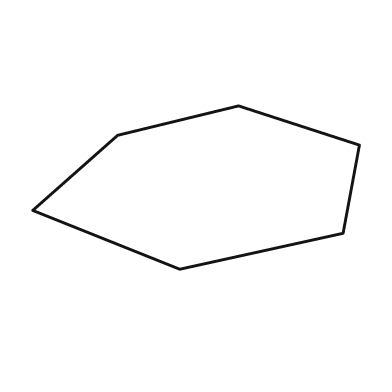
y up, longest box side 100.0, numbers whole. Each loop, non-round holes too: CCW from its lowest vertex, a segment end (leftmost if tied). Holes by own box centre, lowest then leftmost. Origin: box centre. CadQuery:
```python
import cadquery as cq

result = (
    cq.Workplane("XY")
    .moveTo(-5.0, -25.0)
    .lineTo(45.0, -14.0)
    .lineTo(50.0, 13.0)
    .lineTo(13.0, 25.0)
    .lineTo(-24.0, 16.0)
    .lineTo(-50.0, -7.0)
    .close()
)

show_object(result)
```